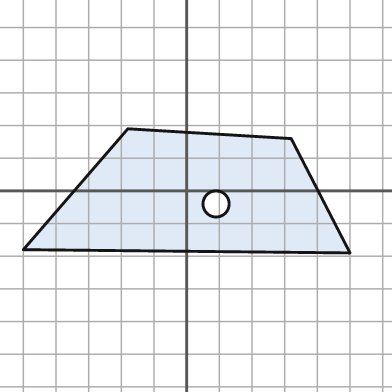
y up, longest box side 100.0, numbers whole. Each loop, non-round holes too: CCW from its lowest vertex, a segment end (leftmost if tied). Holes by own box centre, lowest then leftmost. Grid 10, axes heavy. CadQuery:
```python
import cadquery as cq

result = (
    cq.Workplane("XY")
    .moveTo(50.0, -19.0)
    .lineTo(32.0, 16.0)
    .lineTo(-18.0, 19.0)
    .lineTo(-50.0, -18.0)
    .close()
    .moveTo(9.0, -4.0)
    .circle(4.0)
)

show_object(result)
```